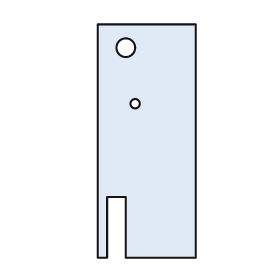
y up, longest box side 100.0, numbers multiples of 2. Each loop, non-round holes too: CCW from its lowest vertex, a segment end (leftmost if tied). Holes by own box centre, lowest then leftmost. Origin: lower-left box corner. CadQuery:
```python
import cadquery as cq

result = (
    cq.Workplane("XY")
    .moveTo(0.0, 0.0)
    .lineTo(4.0, 0.0)
    .lineTo(4.0, 26.0)
    .lineTo(12.0, 26.0)
    .lineTo(12.0, 0.0)
    .lineTo(42.0, 0.0)
    .lineTo(42.0, 100.0)
    .lineTo(0.0, 100.0)
    .close()
    .moveTo(16.0, 66.0)
    .circle(2.0)
    .moveTo(12.0, 90.0)
    .circle(4.0)
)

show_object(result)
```